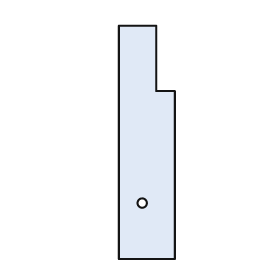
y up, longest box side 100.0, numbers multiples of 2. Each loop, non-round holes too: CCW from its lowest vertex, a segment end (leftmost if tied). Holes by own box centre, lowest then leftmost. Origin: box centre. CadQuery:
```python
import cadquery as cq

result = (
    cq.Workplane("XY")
    .moveTo(-12.0, -50.0)
    .lineTo(12.0, -50.0)
    .lineTo(12.0, 22.0)
    .lineTo(4.0, 22.0)
    .lineTo(4.0, 50.0)
    .lineTo(-12.0, 50.0)
    .close()
    .moveTo(-2.0, -26.0)
    .circle(2.0)
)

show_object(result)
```